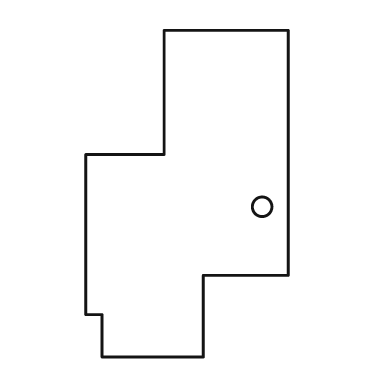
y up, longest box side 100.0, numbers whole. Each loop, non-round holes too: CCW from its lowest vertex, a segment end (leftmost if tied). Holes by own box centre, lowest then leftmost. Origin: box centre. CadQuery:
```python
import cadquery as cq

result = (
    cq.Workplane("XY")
    .moveTo(-26.0, -50.0)
    .lineTo(5.0, -50.0)
    .lineTo(5.0, -25.0)
    .lineTo(31.0, -25.0)
    .lineTo(31.0, 50.0)
    .lineTo(-7.0, 50.0)
    .lineTo(-7.0, 12.0)
    .lineTo(-31.0, 12.0)
    .lineTo(-31.0, -37.0)
    .lineTo(-26.0, -37.0)
    .close()
    .moveTo(23.0, -4.0)
    .circle(3.0)
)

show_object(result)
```